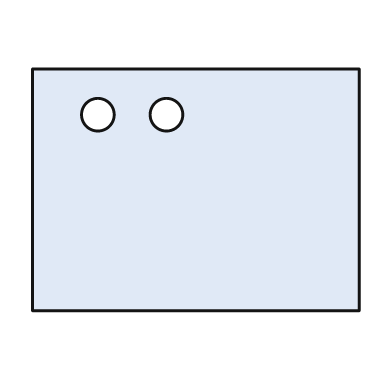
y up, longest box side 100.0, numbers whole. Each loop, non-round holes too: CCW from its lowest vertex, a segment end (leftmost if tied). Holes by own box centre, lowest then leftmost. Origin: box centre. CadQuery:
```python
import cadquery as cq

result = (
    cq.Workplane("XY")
    .moveTo(-50.0, -37.0)
    .lineTo(50.0, -37.0)
    .lineTo(50.0, 37.0)
    .lineTo(-50.0, 37.0)
    .close()
    .moveTo(-30.0, 23.0)
    .circle(5.0)
    .moveTo(-9.0, 23.0)
    .circle(5.0)
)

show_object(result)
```